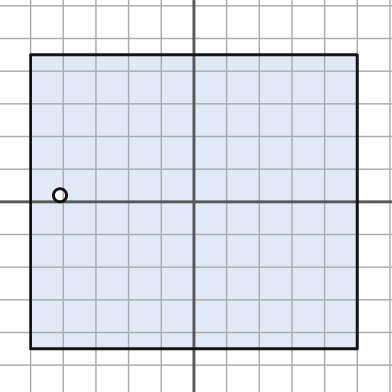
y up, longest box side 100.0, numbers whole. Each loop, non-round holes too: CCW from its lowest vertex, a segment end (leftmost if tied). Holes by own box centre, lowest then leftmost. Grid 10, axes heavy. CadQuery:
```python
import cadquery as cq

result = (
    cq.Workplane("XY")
    .moveTo(-50.0, -45.0)
    .lineTo(50.0, -45.0)
    .lineTo(50.0, 45.0)
    .lineTo(-50.0, 45.0)
    .close()
    .moveTo(-41.0, 2.0)
    .circle(2.0)
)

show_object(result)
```